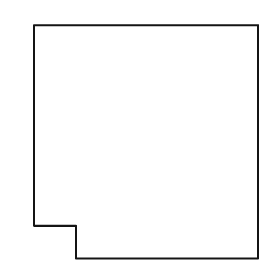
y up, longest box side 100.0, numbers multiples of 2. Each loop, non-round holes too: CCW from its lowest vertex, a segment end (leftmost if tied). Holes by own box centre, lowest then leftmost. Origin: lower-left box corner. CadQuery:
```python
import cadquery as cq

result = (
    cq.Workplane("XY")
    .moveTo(18.0, 0.0)
    .lineTo(96.0, 0.0)
    .lineTo(96.0, 100.0)
    .lineTo(0.0, 100.0)
    .lineTo(0.0, 14.0)
    .lineTo(18.0, 14.0)
    .close()
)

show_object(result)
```